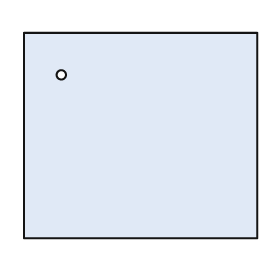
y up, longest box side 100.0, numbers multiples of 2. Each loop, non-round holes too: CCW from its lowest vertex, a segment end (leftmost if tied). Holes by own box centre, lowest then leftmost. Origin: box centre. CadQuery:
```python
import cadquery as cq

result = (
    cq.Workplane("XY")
    .moveTo(-50.0, -44.0)
    .lineTo(50.0, -44.0)
    .lineTo(50.0, 44.0)
    .lineTo(-50.0, 44.0)
    .close()
    .moveTo(-34.0, 26.0)
    .circle(2.0)
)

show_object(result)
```